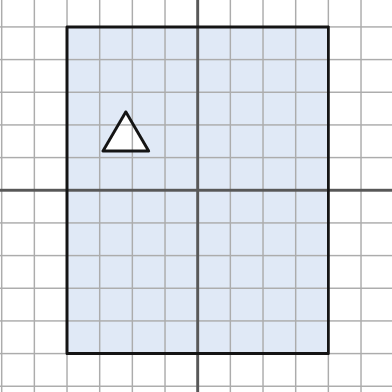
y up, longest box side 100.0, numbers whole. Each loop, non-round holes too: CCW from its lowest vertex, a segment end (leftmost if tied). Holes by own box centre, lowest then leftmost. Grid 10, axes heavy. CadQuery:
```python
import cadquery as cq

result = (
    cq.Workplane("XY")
    .moveTo(-40.0, -50.0)
    .lineTo(40.0, -50.0)
    .lineTo(40.0, 50.0)
    .lineTo(-40.0, 50.0)
    .close()
    .moveTo(-29.0, 12.0)
    .lineTo(-15.0, 12.0)
    .lineTo(-22.0, 24.0)
    .close()
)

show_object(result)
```